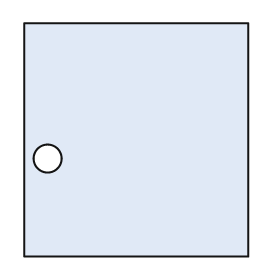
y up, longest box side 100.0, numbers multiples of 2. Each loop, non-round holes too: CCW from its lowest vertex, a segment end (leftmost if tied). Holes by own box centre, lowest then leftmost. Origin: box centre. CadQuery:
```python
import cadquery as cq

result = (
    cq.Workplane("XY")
    .moveTo(-48.0, -50.0)
    .lineTo(48.0, -50.0)
    .lineTo(48.0, 50.0)
    .lineTo(-48.0, 50.0)
    .close()
    .moveTo(-38.0, -8.0)
    .circle(6.0)
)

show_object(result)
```